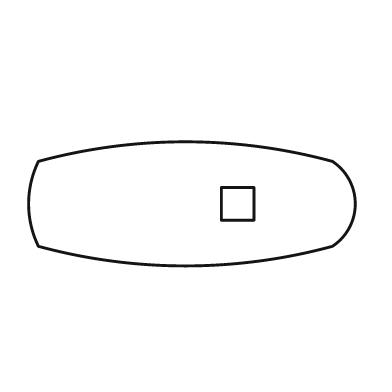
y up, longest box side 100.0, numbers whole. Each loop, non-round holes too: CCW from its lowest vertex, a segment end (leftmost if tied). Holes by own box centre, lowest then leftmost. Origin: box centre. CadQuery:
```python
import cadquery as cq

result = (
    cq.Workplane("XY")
    .moveTo(-47.0, -13.0)
    .threePointArc((-2.0, -19.0), (43.0, -13.0))
    .threePointArc((50.0, 0.0), (43.0, 13.0))
    .threePointArc((-2.0, 19.0), (-47.0, 13.0))
    .threePointArc((-50.0, 0.0), (-47.0, -13.0))
    .close()
    .moveTo(9.0, -5.0)
    .lineTo(19.0, -5.0)
    .lineTo(19.0, 5.0)
    .lineTo(9.0, 5.0)
    .close()
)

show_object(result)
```